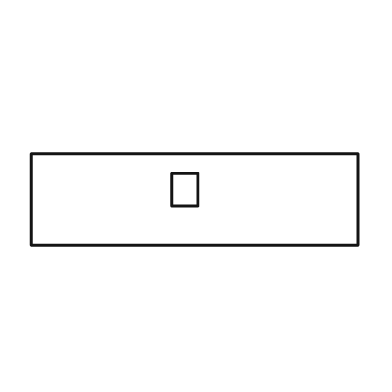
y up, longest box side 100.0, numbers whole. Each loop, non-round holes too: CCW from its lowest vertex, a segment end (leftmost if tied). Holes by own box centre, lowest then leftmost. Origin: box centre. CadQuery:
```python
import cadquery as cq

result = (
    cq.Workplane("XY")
    .moveTo(-50.0, -14.0)
    .lineTo(50.0, -14.0)
    .lineTo(50.0, 14.0)
    .lineTo(-50.0, 14.0)
    .close()
    .moveTo(-7.0, -2.0)
    .lineTo(1.0, -2.0)
    .lineTo(1.0, 8.0)
    .lineTo(-7.0, 8.0)
    .close()
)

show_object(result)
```